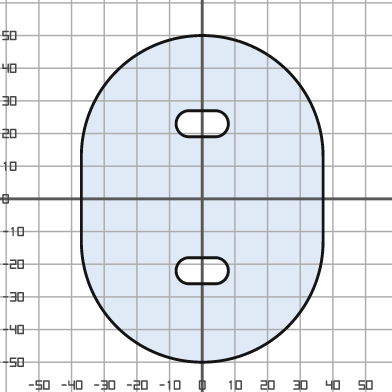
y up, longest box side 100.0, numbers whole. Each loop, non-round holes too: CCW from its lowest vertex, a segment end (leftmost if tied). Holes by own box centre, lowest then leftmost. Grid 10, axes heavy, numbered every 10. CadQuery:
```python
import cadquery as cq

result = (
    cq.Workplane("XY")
    .moveTo(-37.0, -13.0)
    .threePointArc((0.0, -50.0), (37.0, -13.0))
    .lineTo(37.0, 13.0)
    .threePointArc((0.0, 50.0), (-37.0, 13.0))
    .close()
    .moveTo(-4.0, -26.0)
    .lineTo(4.0, -26.0)
    .threePointArc((8.0, -22.0), (4.0, -18.0))
    .lineTo(-4.0, -18.0)
    .threePointArc((-8.0, -22.0), (-4.0, -26.0))
    .close()
    .moveTo(-4.0, 19.0)
    .lineTo(4.0, 19.0)
    .threePointArc((8.0, 23.0), (4.0, 27.0))
    .lineTo(-4.0, 27.0)
    .threePointArc((-8.0, 23.0), (-4.0, 19.0))
    .close()
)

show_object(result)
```